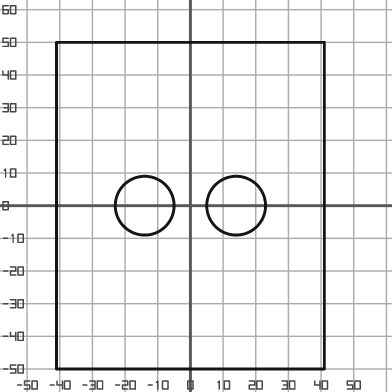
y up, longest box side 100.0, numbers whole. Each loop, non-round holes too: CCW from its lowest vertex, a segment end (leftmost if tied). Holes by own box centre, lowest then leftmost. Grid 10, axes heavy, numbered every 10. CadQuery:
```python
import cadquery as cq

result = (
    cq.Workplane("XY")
    .moveTo(-41.0, -50.0)
    .lineTo(41.0, -50.0)
    .lineTo(41.0, 50.0)
    .lineTo(-41.0, 50.0)
    .close()
    .moveTo(-14.0, 0.0)
    .circle(9.0)
    .moveTo(14.0, 0.0)
    .circle(9.0)
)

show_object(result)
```